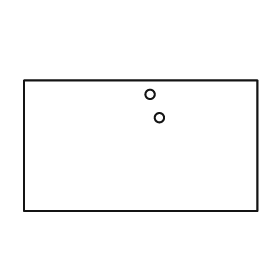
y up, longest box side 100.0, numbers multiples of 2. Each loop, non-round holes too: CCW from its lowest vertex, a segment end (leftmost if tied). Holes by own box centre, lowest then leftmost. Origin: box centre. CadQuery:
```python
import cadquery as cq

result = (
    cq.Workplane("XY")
    .moveTo(-50.0, -28.0)
    .lineTo(50.0, -28.0)
    .lineTo(50.0, 28.0)
    .lineTo(-50.0, 28.0)
    .close()
    .moveTo(8.0, 12.0)
    .circle(2.0)
    .moveTo(4.0, 22.0)
    .circle(2.0)
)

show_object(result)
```